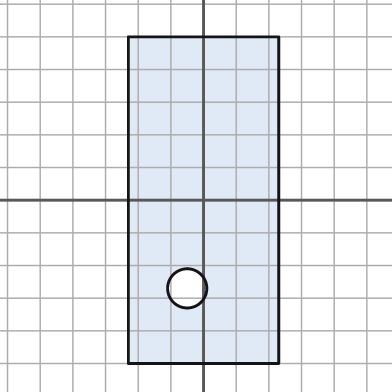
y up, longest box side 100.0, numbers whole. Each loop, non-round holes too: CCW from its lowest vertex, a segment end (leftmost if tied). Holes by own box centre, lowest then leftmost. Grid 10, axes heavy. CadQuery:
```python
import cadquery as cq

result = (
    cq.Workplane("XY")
    .moveTo(-23.0, -50.0)
    .lineTo(23.0, -50.0)
    .lineTo(23.0, 50.0)
    .lineTo(-23.0, 50.0)
    .close()
    .moveTo(-5.0, -27.0)
    .circle(6.0)
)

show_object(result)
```